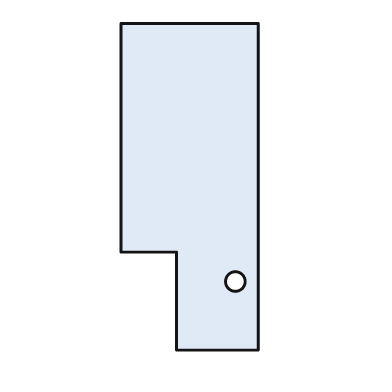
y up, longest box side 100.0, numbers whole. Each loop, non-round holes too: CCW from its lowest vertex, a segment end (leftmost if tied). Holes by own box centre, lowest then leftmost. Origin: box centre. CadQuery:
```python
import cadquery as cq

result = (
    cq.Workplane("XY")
    .moveTo(-4.0, -50.0)
    .lineTo(21.0, -50.0)
    .lineTo(21.0, 50.0)
    .lineTo(-21.0, 50.0)
    .lineTo(-21.0, -20.0)
    .lineTo(-4.0, -20.0)
    .close()
    .moveTo(14.0, -29.0)
    .circle(3.0)
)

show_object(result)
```